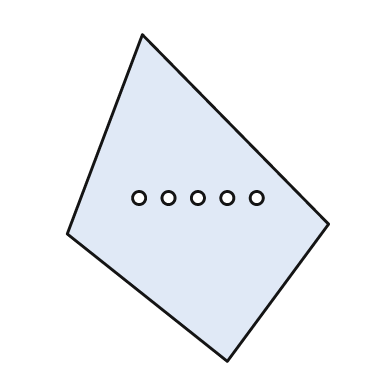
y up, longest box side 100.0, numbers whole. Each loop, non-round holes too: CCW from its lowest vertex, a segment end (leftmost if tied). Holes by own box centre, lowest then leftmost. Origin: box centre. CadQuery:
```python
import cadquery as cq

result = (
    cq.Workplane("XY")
    .moveTo(9.0, -50.0)
    .lineTo(40.0, -8.0)
    .lineTo(-17.0, 50.0)
    .lineTo(-40.0, -11.0)
    .close()
    .moveTo(-18.0, 0.0)
    .circle(2.0)
    .moveTo(-9.0, 0.0)
    .circle(2.0)
    .moveTo(0.0, 0.0)
    .circle(2.0)
    .moveTo(9.0, 0.0)
    .circle(2.0)
    .moveTo(18.0, 0.0)
    .circle(2.0)
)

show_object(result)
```